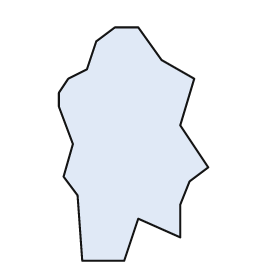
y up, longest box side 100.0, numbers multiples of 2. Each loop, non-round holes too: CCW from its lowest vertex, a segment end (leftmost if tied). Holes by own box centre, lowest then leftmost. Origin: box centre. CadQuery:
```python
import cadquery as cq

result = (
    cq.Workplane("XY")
    .moveTo(-22.0, -50.0)
    .lineTo(-4.0, -50.0)
    .lineTo(2.0, -32.0)
    .lineTo(20.0, -40.0)
    .lineTo(20.0, -26.0)
    .lineTo(24.0, -16.0)
    .lineTo(32.0, -10.0)
    .lineTo(20.0, 8.0)
    .lineTo(26.0, 28.0)
    .lineTo(12.0, 36.0)
    .lineTo(2.0, 50.0)
    .lineTo(-8.0, 50.0)
    .lineTo(-16.0, 44.0)
    .lineTo(-20.0, 32.0)
    .lineTo(-28.0, 28.0)
    .lineTo(-32.0, 22.0)
    .lineTo(-32.0, 16.0)
    .lineTo(-26.0, 0.0)
    .lineTo(-30.0, -14.0)
    .lineTo(-24.0, -22.0)
    .close()
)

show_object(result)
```